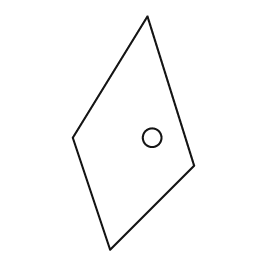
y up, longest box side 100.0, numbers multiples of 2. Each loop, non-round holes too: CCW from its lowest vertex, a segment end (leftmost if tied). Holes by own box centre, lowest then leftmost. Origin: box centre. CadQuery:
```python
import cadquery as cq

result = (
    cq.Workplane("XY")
    .moveTo(-10.0, -50.0)
    .lineTo(26.0, -14.0)
    .lineTo(6.0, 50.0)
    .lineTo(-26.0, -2.0)
    .close()
    .moveTo(8.0, -2.0)
    .circle(4.0)
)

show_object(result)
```